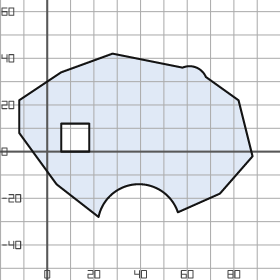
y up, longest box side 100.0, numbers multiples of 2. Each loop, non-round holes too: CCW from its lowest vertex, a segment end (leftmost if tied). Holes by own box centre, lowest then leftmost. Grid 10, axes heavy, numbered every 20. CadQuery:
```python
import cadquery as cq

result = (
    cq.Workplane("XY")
    .moveTo(22.0, -28.0)
    .threePointArc((38.0, -14.0), (56.0, -26.0))
    .lineTo(74.0, -18.0)
    .lineTo(88.0, -2.0)
    .lineTo(82.0, 22.0)
    .lineTo(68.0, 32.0)
    .threePointArc((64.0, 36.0), (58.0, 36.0))
    .lineTo(28.0, 42.0)
    .lineTo(6.0, 34.0)
    .lineTo(-12.0, 22.0)
    .lineTo(-12.0, 8.0)
    .lineTo(4.0, -14.0)
    .close()
    .moveTo(6.0, 0.0)
    .lineTo(18.0, 0.0)
    .lineTo(18.0, 12.0)
    .lineTo(6.0, 12.0)
    .close()
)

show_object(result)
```